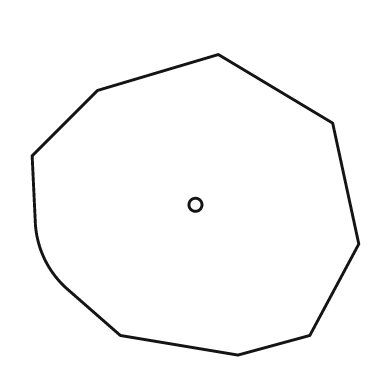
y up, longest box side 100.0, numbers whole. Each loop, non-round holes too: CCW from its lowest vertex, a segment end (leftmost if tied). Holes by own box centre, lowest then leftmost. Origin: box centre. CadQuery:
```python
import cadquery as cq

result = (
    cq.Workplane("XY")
    .moveTo(13.0, -46.0)
    .lineTo(35.0, -40.0)
    .lineTo(50.0, -12.0)
    .lineTo(42.0, 25.0)
    .lineTo(7.0, 46.0)
    .lineTo(-30.0, 35.0)
    .lineTo(-50.0, 15.0)
    .lineTo(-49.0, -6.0)
    .threePointArc((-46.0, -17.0), (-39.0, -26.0))
    .lineTo(-23.0, -40.0)
    .close()
    .moveTo(0.0, 0.0)
    .circle(2.0)
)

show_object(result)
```